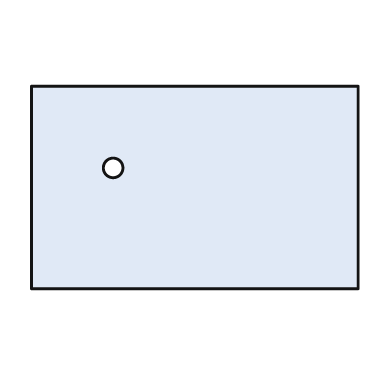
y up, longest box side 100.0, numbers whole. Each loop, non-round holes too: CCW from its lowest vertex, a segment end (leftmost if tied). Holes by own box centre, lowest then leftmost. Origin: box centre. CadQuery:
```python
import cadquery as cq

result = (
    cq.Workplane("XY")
    .moveTo(-50.0, -31.0)
    .lineTo(50.0, -31.0)
    .lineTo(50.0, 31.0)
    .lineTo(-50.0, 31.0)
    .close()
    .moveTo(-25.0, 6.0)
    .circle(3.0)
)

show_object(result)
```